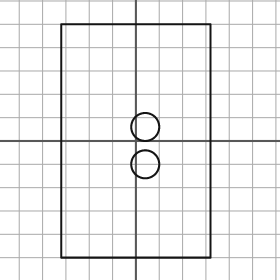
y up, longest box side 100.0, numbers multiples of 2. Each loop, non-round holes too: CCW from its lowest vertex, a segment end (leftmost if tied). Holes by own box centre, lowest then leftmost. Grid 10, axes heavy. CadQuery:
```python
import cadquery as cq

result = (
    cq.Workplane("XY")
    .moveTo(-32.0, -50.0)
    .lineTo(32.0, -50.0)
    .lineTo(32.0, 50.0)
    .lineTo(-32.0, 50.0)
    .close()
    .moveTo(4.0, -10.0)
    .circle(6.0)
    .moveTo(4.0, 6.0)
    .circle(6.0)
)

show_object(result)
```